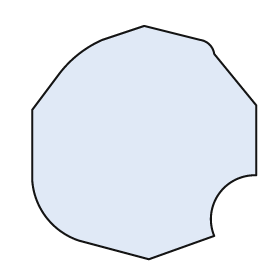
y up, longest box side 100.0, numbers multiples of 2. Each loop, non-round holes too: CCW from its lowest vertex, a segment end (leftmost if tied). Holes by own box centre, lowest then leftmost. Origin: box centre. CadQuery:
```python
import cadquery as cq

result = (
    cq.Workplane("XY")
    .moveTo(2.0, -50.0)
    .lineTo(30.0, -40.0)
    .threePointArc((32.0, -22.0), (48.0, -14.0))
    .lineTo(48.0, 16.0)
    .lineTo(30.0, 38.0)
    .threePointArc((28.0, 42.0), (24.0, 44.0))
    .lineTo(0.0, 50.0)
    .lineTo(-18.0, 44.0)
    .threePointArc((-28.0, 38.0), (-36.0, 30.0))
    .lineTo(-48.0, 14.0)
    .lineTo(-48.0, -16.0)
    .threePointArc((-42.0, -32.0), (-28.0, -42.0))
    .close()
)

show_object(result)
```